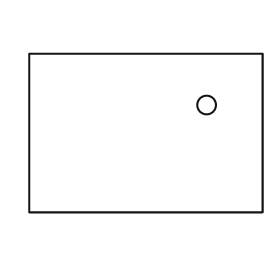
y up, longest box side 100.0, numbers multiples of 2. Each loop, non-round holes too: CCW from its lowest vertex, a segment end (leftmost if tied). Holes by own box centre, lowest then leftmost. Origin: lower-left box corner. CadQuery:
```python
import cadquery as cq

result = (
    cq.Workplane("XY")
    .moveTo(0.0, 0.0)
    .lineTo(100.0, 0.0)
    .lineTo(100.0, 68.0)
    .lineTo(0.0, 68.0)
    .close()
    .moveTo(76.0, 46.0)
    .circle(4.0)
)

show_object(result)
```